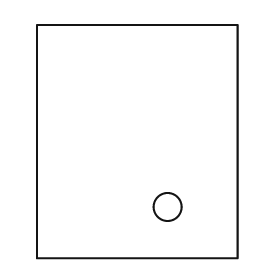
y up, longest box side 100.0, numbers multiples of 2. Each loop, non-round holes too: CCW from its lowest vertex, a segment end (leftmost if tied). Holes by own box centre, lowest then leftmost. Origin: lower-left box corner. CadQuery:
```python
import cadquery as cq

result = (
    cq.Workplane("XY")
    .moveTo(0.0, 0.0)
    .lineTo(86.0, 0.0)
    .lineTo(86.0, 100.0)
    .lineTo(0.0, 100.0)
    .close()
    .moveTo(56.0, 22.0)
    .circle(6.0)
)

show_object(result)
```